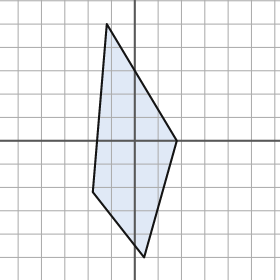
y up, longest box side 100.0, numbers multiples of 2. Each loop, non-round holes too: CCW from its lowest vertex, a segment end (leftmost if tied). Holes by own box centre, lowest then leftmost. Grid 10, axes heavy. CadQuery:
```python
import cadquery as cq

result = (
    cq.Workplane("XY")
    .moveTo(4.0, -50.0)
    .lineTo(18.0, 0.0)
    .lineTo(-12.0, 50.0)
    .lineTo(-18.0, -22.0)
    .close()
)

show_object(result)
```